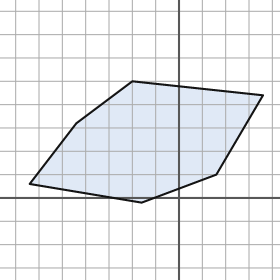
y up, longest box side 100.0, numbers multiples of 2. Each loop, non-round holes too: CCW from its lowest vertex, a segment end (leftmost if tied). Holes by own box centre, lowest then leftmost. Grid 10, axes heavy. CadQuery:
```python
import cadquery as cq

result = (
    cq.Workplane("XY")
    .moveTo(-16.0, -2.0)
    .lineTo(16.0, 10.0)
    .lineTo(36.0, 44.0)
    .lineTo(-20.0, 50.0)
    .lineTo(-44.0, 32.0)
    .lineTo(-64.0, 6.0)
    .close()
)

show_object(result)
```